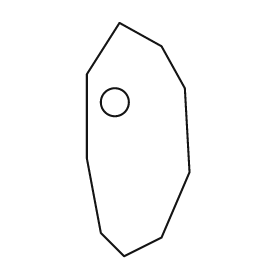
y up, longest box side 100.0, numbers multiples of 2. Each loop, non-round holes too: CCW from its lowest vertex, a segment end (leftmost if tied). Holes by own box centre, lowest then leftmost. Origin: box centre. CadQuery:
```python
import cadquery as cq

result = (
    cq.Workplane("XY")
    .moveTo(-6.0, -50.0)
    .lineTo(10.0, -42.0)
    .lineTo(22.0, -14.0)
    .lineTo(20.0, 22.0)
    .lineTo(10.0, 40.0)
    .lineTo(-8.0, 50.0)
    .lineTo(-22.0, 28.0)
    .lineTo(-22.0, -8.0)
    .lineTo(-16.0, -40.0)
    .close()
    .moveTo(-10.0, 16.0)
    .circle(6.0)
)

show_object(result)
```